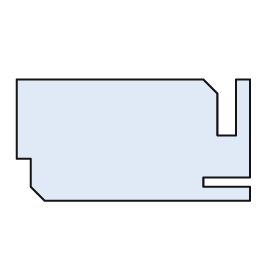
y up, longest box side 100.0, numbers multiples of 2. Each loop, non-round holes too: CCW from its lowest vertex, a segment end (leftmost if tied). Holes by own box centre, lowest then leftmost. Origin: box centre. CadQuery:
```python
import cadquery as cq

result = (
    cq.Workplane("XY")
    .moveTo(-38.0, -26.0)
    .lineTo(50.0, -26.0)
    .lineTo(50.0, -20.0)
    .lineTo(30.0, -20.0)
    .lineTo(30.0, -16.0)
    .lineTo(50.0, -16.0)
    .lineTo(50.0, 26.0)
    .lineTo(44.0, 26.0)
    .lineTo(44.0, 2.0)
    .lineTo(36.0, 2.0)
    .lineTo(36.0, 20.0)
    .lineTo(30.0, 26.0)
    .lineTo(-50.0, 26.0)
    .lineTo(-50.0, -8.0)
    .lineTo(-44.0, -8.0)
    .lineTo(-44.0, -20.0)
    .close()
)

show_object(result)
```